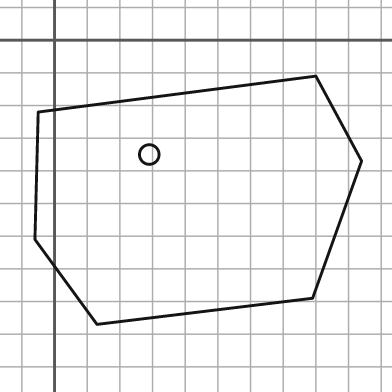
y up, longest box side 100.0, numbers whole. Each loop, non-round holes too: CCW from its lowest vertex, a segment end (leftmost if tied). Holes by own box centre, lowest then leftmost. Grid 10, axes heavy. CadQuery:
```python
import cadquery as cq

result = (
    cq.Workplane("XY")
    .moveTo(13.0, -87.0)
    .lineTo(79.0, -79.0)
    .lineTo(94.0, -37.0)
    .lineTo(80.0, -11.0)
    .lineTo(-5.0, -22.0)
    .lineTo(-6.0, -61.0)
    .close()
    .moveTo(29.0, -35.0)
    .circle(3.0)
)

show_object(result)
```